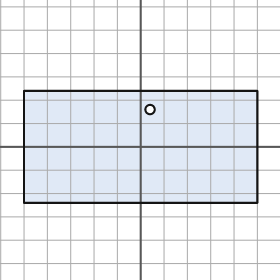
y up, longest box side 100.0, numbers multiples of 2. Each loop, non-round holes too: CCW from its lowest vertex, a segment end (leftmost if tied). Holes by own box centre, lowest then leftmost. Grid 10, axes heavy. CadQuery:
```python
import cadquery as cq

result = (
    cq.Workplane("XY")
    .moveTo(-50.0, -24.0)
    .lineTo(50.0, -24.0)
    .lineTo(50.0, 24.0)
    .lineTo(-50.0, 24.0)
    .close()
    .moveTo(4.0, 16.0)
    .circle(2.0)
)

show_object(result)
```